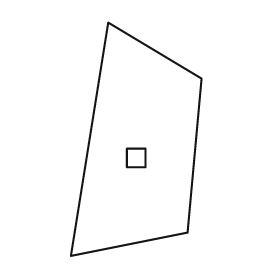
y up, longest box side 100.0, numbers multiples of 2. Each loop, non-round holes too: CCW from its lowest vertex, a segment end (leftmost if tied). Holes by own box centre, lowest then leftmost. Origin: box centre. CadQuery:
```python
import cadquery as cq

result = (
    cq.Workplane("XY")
    .moveTo(-28.0, -50.0)
    .lineTo(22.0, -40.0)
    .lineTo(28.0, 26.0)
    .lineTo(-12.0, 50.0)
    .close()
    .moveTo(-4.0, -12.0)
    .lineTo(4.0, -12.0)
    .lineTo(4.0, -4.0)
    .lineTo(-4.0, -4.0)
    .close()
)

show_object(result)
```